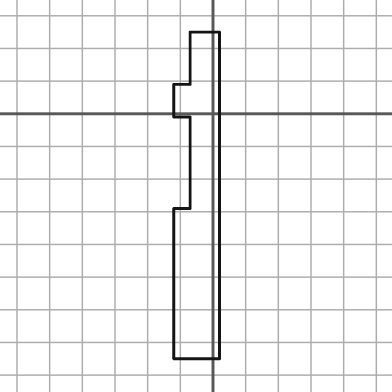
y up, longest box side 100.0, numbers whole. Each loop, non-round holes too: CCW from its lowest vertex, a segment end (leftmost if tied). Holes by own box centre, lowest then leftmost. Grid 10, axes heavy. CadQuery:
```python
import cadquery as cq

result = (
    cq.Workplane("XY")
    .moveTo(-12.0, -75.0)
    .lineTo(2.0, -75.0)
    .lineTo(2.0, 25.0)
    .lineTo(-7.0, 25.0)
    .lineTo(-7.0, 9.0)
    .lineTo(-12.0, 9.0)
    .lineTo(-12.0, -1.0)
    .lineTo(-7.0, -1.0)
    .lineTo(-7.0, -29.0)
    .lineTo(-12.0, -29.0)
    .close()
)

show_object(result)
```